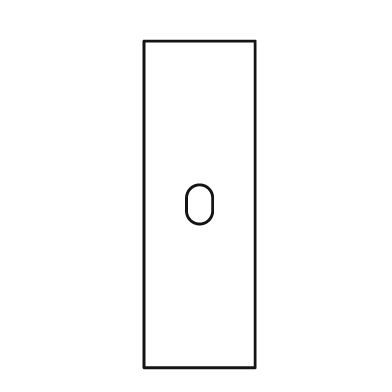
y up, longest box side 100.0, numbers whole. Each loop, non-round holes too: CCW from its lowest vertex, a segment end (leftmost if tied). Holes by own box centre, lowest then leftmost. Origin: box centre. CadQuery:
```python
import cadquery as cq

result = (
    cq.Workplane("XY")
    .moveTo(-17.0, -50.0)
    .lineTo(17.0, -50.0)
    .lineTo(17.0, 50.0)
    .lineTo(-17.0, 50.0)
    .close()
    .moveTo(-4.0, -2.0)
    .threePointArc((0.0, -6.0), (4.0, -2.0))
    .lineTo(4.0, 2.0)
    .threePointArc((0.0, 6.0), (-4.0, 2.0))
    .close()
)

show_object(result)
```